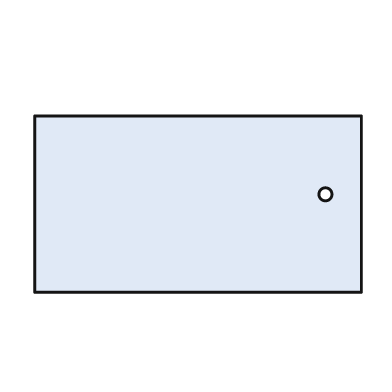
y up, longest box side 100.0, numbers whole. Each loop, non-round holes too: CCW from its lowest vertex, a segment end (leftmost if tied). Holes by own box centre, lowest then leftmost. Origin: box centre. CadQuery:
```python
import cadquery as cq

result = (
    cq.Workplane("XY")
    .moveTo(-50.0, -27.0)
    .lineTo(50.0, -27.0)
    .lineTo(50.0, 27.0)
    .lineTo(-50.0, 27.0)
    .close()
    .moveTo(39.0, 3.0)
    .circle(2.0)
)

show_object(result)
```